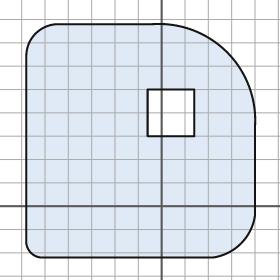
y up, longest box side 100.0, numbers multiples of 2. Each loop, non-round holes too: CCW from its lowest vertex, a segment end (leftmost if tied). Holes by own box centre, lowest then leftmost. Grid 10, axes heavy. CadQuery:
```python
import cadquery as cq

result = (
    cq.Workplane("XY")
    .moveTo(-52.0, -22.0)
    .lineTo(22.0, -22.0)
    .threePointArc((34.0, -16.0), (40.0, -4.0))
    .lineTo(40.0, 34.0)
    .threePointArc((28.0, 66.0), (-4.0, 78.0))
    .lineTo(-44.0, 78.0)
    .threePointArc((-54.0, 74.0), (-58.0, 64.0))
    .lineTo(-58.0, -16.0)
    .threePointArc((-56.0, -20.0), (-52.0, -22.0))
    .close()
    .moveTo(-6.0, 30.0)
    .lineTo(14.0, 30.0)
    .lineTo(14.0, 50.0)
    .lineTo(-6.0, 50.0)
    .close()
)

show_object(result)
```